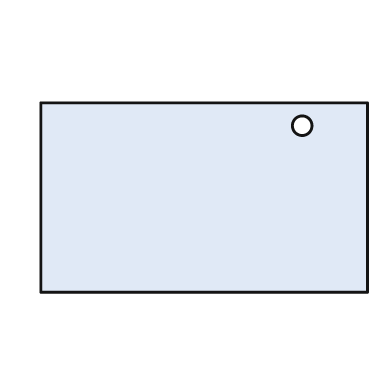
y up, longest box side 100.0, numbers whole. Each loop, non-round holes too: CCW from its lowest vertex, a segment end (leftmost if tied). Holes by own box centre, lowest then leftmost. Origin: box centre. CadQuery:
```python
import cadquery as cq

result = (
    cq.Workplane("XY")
    .moveTo(-50.0, -29.0)
    .lineTo(50.0, -29.0)
    .lineTo(50.0, 29.0)
    .lineTo(-50.0, 29.0)
    .close()
    .moveTo(30.0, 22.0)
    .circle(3.0)
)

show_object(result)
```